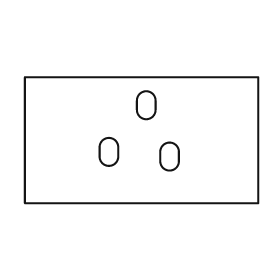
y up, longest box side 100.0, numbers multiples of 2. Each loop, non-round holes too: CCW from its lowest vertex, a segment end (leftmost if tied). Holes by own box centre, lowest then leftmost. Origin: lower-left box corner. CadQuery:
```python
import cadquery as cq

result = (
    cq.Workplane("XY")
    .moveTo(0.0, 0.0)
    .lineTo(100.0, 0.0)
    .lineTo(100.0, 54.0)
    .lineTo(0.0, 54.0)
    .close()
    .moveTo(58.0, 18.0)
    .threePointArc((62.0, 14.0), (66.0, 18.0))
    .lineTo(66.0, 22.0)
    .threePointArc((62.0, 26.0), (58.0, 22.0))
    .close()
    .moveTo(32.0, 20.0)
    .threePointArc((36.0, 16.0), (40.0, 20.0))
    .lineTo(40.0, 24.0)
    .threePointArc((36.0, 28.0), (32.0, 24.0))
    .close()
    .moveTo(48.0, 40.0)
    .threePointArc((52.0, 36.0), (56.0, 40.0))
    .lineTo(56.0, 44.0)
    .threePointArc((52.0, 48.0), (48.0, 44.0))
    .close()
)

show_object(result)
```